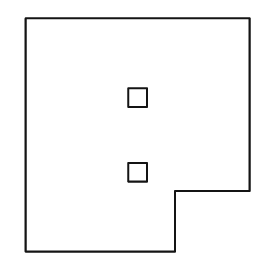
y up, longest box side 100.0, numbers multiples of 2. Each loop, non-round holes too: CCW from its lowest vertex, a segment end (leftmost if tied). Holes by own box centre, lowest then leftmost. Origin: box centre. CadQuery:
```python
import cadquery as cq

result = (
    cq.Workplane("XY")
    .moveTo(-48.0, -50.0)
    .lineTo(16.0, -50.0)
    .lineTo(16.0, -24.0)
    .lineTo(48.0, -24.0)
    .lineTo(48.0, 50.0)
    .lineTo(-48.0, 50.0)
    .close()
    .moveTo(-4.0, -20.0)
    .lineTo(4.0, -20.0)
    .lineTo(4.0, -12.0)
    .lineTo(-4.0, -12.0)
    .close()
    .moveTo(-4.0, 12.0)
    .lineTo(4.0, 12.0)
    .lineTo(4.0, 20.0)
    .lineTo(-4.0, 20.0)
    .close()
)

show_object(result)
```